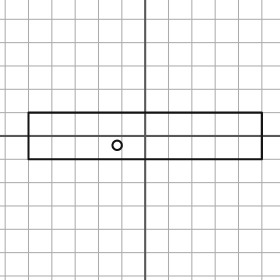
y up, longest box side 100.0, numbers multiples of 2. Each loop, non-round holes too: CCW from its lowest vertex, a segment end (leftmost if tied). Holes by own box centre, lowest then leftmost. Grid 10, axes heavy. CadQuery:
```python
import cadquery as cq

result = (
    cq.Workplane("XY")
    .moveTo(-50.0, -10.0)
    .lineTo(50.0, -10.0)
    .lineTo(50.0, 10.0)
    .lineTo(-50.0, 10.0)
    .close()
    .moveTo(-12.0, -4.0)
    .circle(2.0)
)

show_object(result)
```